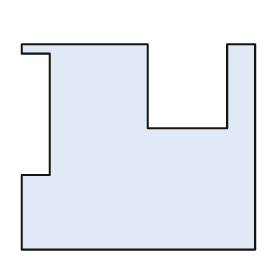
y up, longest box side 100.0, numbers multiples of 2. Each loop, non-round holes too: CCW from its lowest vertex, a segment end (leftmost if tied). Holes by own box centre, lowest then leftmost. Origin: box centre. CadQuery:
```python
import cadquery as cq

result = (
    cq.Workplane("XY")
    .moveTo(-50.0, -44.0)
    .lineTo(50.0, -44.0)
    .lineTo(50.0, 44.0)
    .lineTo(38.0, 44.0)
    .lineTo(38.0, 8.0)
    .lineTo(4.0, 8.0)
    .lineTo(4.0, 44.0)
    .lineTo(-50.0, 44.0)
    .lineTo(-50.0, 40.0)
    .lineTo(-38.0, 40.0)
    .lineTo(-38.0, -12.0)
    .lineTo(-50.0, -12.0)
    .close()
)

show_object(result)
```